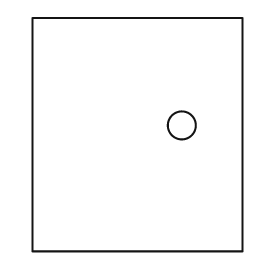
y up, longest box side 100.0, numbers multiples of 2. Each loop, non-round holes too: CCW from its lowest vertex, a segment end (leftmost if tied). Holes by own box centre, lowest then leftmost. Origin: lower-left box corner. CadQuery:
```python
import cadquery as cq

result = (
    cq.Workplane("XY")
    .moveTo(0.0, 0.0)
    .lineTo(90.0, 0.0)
    .lineTo(90.0, 100.0)
    .lineTo(0.0, 100.0)
    .close()
    .moveTo(64.0, 54.0)
    .circle(6.0)
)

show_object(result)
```